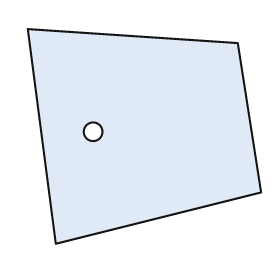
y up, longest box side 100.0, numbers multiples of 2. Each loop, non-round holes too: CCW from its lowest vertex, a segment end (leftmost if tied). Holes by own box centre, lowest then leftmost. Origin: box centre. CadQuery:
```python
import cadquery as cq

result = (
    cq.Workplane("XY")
    .moveTo(-38.0, -46.0)
    .lineTo(50.0, -24.0)
    .lineTo(40.0, 40.0)
    .lineTo(-50.0, 46.0)
    .close()
    .moveTo(-22.0, 2.0)
    .circle(4.0)
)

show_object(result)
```